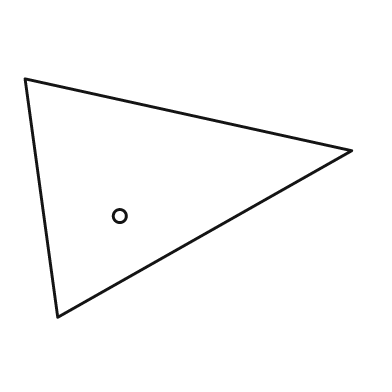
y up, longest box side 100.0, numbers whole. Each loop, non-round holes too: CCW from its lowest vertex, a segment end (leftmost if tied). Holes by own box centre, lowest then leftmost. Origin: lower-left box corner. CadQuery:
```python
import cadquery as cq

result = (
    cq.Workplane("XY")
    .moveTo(10.0, 0.0)
    .lineTo(100.0, 51.0)
    .lineTo(0.0, 73.0)
    .close()
    .moveTo(29.0, 31.0)
    .circle(2.0)
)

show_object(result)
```